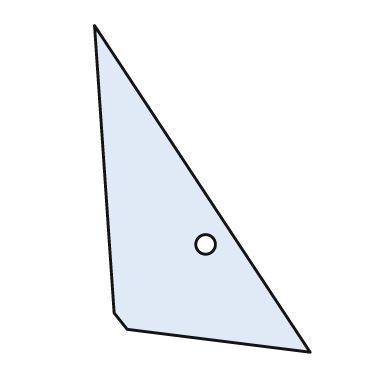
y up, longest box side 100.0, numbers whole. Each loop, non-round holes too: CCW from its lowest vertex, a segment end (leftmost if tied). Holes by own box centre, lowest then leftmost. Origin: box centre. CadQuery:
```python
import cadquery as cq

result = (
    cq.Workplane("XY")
    .moveTo(33.0, -50.0)
    .lineTo(-33.0, 50.0)
    .lineTo(-27.0, -38.0)
    .lineTo(-23.0, -43.0)
    .close()
    .moveTo(1.0, -17.0)
    .circle(3.0)
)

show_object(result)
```